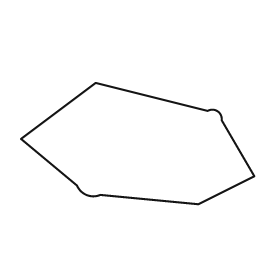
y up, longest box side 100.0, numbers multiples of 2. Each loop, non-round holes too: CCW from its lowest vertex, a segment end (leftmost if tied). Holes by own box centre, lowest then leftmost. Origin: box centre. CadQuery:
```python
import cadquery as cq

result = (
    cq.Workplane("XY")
    .moveTo(26.0, -26.0)
    .lineTo(50.0, -14.0)
    .lineTo(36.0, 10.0)
    .threePointArc((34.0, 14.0), (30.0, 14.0))
    .lineTo(-18.0, 26.0)
    .lineTo(-50.0, 2.0)
    .lineTo(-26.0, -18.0)
    .threePointArc((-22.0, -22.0), (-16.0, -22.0))
    .close()
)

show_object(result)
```